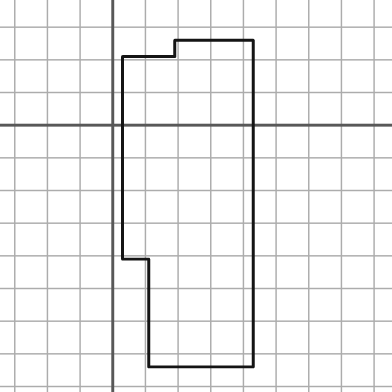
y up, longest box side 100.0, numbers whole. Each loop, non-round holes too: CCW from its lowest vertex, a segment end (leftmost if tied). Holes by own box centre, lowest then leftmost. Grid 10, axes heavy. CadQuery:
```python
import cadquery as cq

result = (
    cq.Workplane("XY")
    .moveTo(11.0, -74.0)
    .lineTo(43.0, -74.0)
    .lineTo(43.0, 26.0)
    .lineTo(19.0, 26.0)
    .lineTo(19.0, 21.0)
    .lineTo(3.0, 21.0)
    .lineTo(3.0, -41.0)
    .lineTo(11.0, -41.0)
    .close()
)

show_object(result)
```